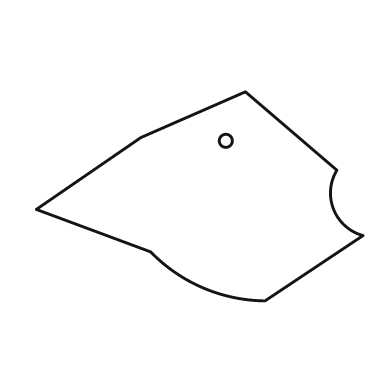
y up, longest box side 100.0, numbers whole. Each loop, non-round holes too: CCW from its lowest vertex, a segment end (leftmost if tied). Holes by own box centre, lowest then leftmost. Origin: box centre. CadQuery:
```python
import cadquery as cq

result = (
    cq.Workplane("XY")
    .moveTo(20.0, -32.0)
    .lineTo(50.0, -12.0)
    .threePointArc((41.0, -4.0), (42.0, 8.0))
    .lineTo(14.0, 32.0)
    .lineTo(-18.0, 18.0)
    .lineTo(-50.0, -4.0)
    .lineTo(-15.0, -17.0)
    .threePointArc((1.0, -28.0), (20.0, -32.0))
    .close()
    .moveTo(8.0, 17.0)
    .circle(2.0)
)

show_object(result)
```